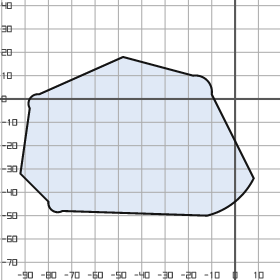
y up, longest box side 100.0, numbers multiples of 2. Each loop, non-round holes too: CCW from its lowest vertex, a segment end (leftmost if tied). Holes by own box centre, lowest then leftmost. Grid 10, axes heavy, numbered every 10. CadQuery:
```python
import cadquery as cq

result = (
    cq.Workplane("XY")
    .moveTo(-12.0, -50.0)
    .threePointArc((0.0, -44.0), (8.0, -34.0))
    .lineTo(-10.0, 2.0)
    .threePointArc((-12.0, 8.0), (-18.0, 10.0))
    .lineTo(-48.0, 18.0)
    .lineTo(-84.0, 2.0)
    .threePointArc((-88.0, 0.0), (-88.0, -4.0))
    .lineTo(-92.0, -32.0)
    .lineTo(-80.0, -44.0)
    .threePointArc((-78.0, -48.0), (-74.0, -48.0))
    .close()
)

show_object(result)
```